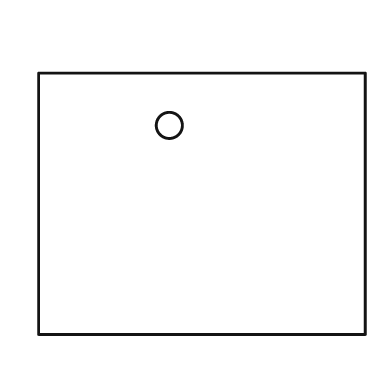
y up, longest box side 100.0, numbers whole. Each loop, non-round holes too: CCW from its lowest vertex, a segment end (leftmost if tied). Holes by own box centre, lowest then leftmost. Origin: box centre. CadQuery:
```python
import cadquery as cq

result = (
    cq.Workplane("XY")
    .moveTo(-50.0, -40.0)
    .lineTo(50.0, -40.0)
    .lineTo(50.0, 40.0)
    .lineTo(-50.0, 40.0)
    .close()
    .moveTo(-10.0, 24.0)
    .circle(4.0)
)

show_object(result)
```